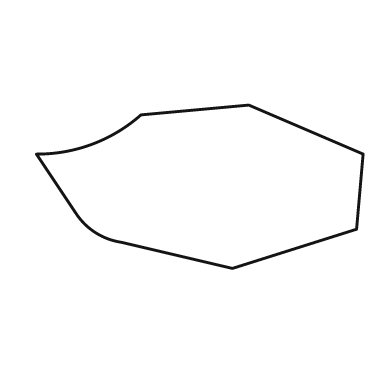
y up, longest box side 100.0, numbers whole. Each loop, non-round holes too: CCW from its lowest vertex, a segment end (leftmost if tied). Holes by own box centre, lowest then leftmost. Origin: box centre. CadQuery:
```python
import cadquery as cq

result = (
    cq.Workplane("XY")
    .moveTo(10.0, -25.0)
    .lineTo(48.0, -13.0)
    .lineTo(50.0, 10.0)
    .lineTo(15.0, 25.0)
    .lineTo(-18.0, 22.0)
    .threePointArc((-33.0, 13.0), (-50.0, 10.0))
    .lineTo(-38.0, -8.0)
    .threePointArc((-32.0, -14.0), (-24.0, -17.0))
    .close()
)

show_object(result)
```